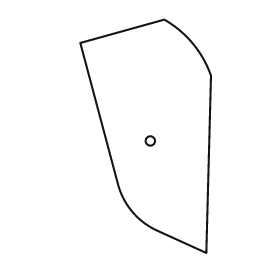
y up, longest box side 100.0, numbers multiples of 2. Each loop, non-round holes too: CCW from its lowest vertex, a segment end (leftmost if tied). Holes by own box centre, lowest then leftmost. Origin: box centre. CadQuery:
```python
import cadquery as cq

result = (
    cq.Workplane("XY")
    .moveTo(26.0, -50.0)
    .lineTo(28.0, 26.0)
    .threePointArc((20.0, 40.0), (8.0, 50.0))
    .lineTo(-28.0, 40.0)
    .lineTo(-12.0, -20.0)
    .threePointArc((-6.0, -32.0), (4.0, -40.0))
    .close()
    .moveTo(2.0, -2.0)
    .circle(2.0)
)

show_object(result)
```